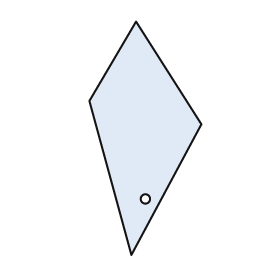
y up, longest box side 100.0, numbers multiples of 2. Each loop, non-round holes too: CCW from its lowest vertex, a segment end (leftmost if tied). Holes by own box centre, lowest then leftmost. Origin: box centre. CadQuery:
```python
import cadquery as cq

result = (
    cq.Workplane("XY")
    .moveTo(-6.0, -50.0)
    .lineTo(24.0, 6.0)
    .lineTo(-4.0, 50.0)
    .lineTo(-24.0, 16.0)
    .close()
    .moveTo(0.0, -26.0)
    .circle(2.0)
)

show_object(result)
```